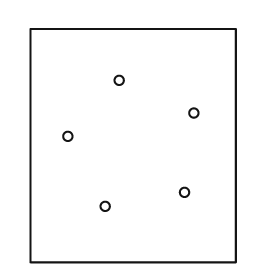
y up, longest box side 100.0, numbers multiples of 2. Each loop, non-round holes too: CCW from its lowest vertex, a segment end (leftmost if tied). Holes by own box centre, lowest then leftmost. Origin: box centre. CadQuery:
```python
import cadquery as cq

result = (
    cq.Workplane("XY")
    .moveTo(-44.0, -50.0)
    .lineTo(44.0, -50.0)
    .lineTo(44.0, 50.0)
    .lineTo(-44.0, 50.0)
    .close()
    .moveTo(-12.0, -26.0)
    .circle(2.0)
    .moveTo(22.0, -20.0)
    .circle(2.0)
    .moveTo(-28.0, 4.0)
    .circle(2.0)
    .moveTo(26.0, 14.0)
    .circle(2.0)
    .moveTo(-6.0, 28.0)
    .circle(2.0)
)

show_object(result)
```